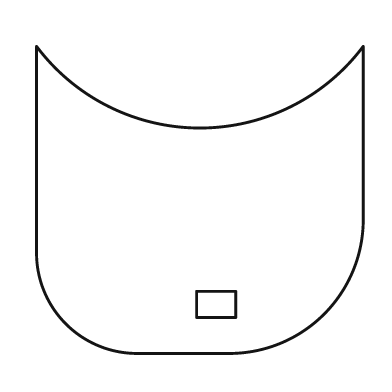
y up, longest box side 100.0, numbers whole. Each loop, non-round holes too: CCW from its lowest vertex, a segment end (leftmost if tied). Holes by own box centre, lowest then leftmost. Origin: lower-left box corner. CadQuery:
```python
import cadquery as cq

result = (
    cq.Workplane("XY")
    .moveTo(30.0, 0.0)
    .lineTo(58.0, 0.0)
    .threePointArc((88.0, 12.0), (100.0, 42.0))
    .lineTo(100.0, 94.0)
    .threePointArc((50.0, 69.0), (0.0, 94.0))
    .lineTo(0.0, 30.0)
    .threePointArc((9.0, 9.0), (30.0, 0.0))
    .close()
    .moveTo(49.0, 11.0)
    .lineTo(61.0, 11.0)
    .lineTo(61.0, 19.0)
    .lineTo(49.0, 19.0)
    .close()
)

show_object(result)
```